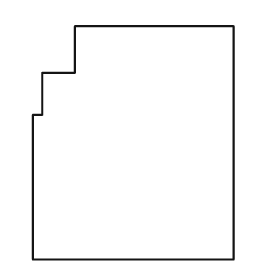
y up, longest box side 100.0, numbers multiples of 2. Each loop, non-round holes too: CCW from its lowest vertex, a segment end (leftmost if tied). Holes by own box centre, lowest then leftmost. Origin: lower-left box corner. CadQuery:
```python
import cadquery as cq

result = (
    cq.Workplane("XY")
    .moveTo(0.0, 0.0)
    .lineTo(86.0, 0.0)
    .lineTo(86.0, 100.0)
    .lineTo(18.0, 100.0)
    .lineTo(18.0, 80.0)
    .lineTo(4.0, 80.0)
    .lineTo(4.0, 62.0)
    .lineTo(0.0, 62.0)
    .close()
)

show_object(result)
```